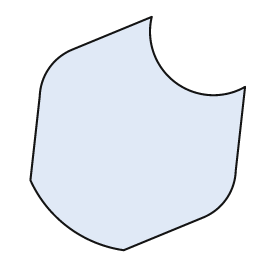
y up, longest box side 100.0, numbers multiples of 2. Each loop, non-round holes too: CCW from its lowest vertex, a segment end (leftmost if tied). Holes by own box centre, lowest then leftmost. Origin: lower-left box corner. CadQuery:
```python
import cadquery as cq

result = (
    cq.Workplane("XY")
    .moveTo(40.0, 0.0)
    .lineTo(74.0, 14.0)
    .threePointArc((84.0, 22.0), (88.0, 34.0))
    .lineTo(92.0, 70.0)
    .threePointArc((62.0, 72.0), (52.0, 100.0))
    .lineTo(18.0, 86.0)
    .threePointArc((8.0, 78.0), (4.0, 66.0))
    .lineTo(0.0, 30.0)
    .threePointArc((16.0, 10.0), (40.0, 0.0))
    .close()
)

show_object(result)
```